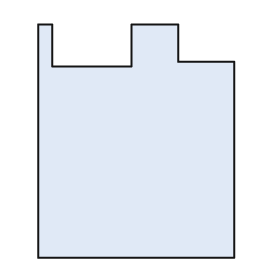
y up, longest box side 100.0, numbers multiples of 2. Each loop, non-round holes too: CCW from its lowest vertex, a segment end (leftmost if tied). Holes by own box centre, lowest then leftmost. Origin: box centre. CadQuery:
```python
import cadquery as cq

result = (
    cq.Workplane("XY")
    .moveTo(-42.0, -50.0)
    .lineTo(42.0, -50.0)
    .lineTo(42.0, 34.0)
    .lineTo(18.0, 34.0)
    .lineTo(18.0, 50.0)
    .lineTo(-2.0, 50.0)
    .lineTo(-2.0, 32.0)
    .lineTo(-36.0, 32.0)
    .lineTo(-36.0, 50.0)
    .lineTo(-42.0, 50.0)
    .close()
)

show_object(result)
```